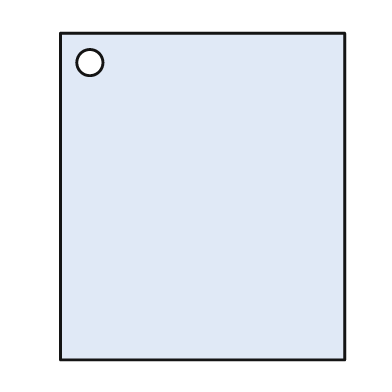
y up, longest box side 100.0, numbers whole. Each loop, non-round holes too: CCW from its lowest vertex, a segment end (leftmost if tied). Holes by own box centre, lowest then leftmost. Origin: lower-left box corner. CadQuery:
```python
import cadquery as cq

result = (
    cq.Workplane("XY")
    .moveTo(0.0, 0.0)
    .lineTo(87.0, 0.0)
    .lineTo(87.0, 100.0)
    .lineTo(0.0, 100.0)
    .close()
    .moveTo(9.0, 91.0)
    .circle(4.0)
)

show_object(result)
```